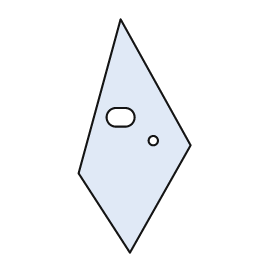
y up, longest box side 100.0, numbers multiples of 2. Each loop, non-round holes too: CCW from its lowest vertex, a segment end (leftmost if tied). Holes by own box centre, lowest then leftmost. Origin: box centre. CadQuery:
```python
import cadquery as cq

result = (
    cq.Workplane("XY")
    .moveTo(-2.0, -50.0)
    .lineTo(24.0, -4.0)
    .lineTo(-6.0, 50.0)
    .lineTo(-24.0, -16.0)
    .close()
    .moveTo(8.0, -2.0)
    .circle(2.0)
    .moveTo(-8.0, 4.0)
    .lineTo(-4.0, 4.0)
    .threePointArc((0.0, 8.0), (-4.0, 12.0))
    .lineTo(-8.0, 12.0)
    .threePointArc((-12.0, 8.0), (-8.0, 4.0))
    .close()
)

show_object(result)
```